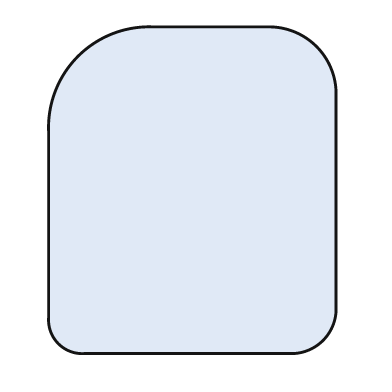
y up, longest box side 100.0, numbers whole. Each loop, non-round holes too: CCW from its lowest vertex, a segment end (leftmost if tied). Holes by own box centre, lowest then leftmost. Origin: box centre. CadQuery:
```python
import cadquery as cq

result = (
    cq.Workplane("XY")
    .moveTo(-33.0, -50.0)
    .lineTo(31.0, -50.0)
    .threePointArc((40.0, -46.0), (44.0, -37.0))
    .lineTo(44.0, 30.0)
    .threePointArc((38.0, 44.0), (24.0, 50.0))
    .lineTo(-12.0, 50.0)
    .threePointArc((-35.0, 41.0), (-44.0, 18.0))
    .lineTo(-44.0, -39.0)
    .threePointArc((-41.0, -47.0), (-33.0, -50.0))
    .close()
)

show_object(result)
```